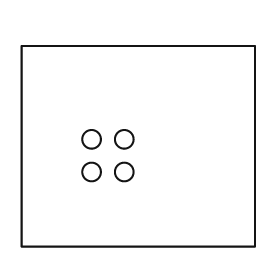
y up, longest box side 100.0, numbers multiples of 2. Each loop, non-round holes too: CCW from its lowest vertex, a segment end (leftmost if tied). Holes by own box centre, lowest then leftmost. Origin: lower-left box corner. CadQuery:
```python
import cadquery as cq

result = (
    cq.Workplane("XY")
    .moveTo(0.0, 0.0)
    .lineTo(100.0, 0.0)
    .lineTo(100.0, 86.0)
    .lineTo(0.0, 86.0)
    .close()
    .moveTo(30.0, 32.0)
    .circle(4.0)
    .moveTo(44.0, 32.0)
    .circle(4.0)
    .moveTo(30.0, 46.0)
    .circle(4.0)
    .moveTo(44.0, 46.0)
    .circle(4.0)
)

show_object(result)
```